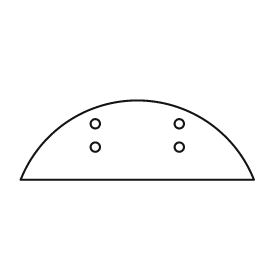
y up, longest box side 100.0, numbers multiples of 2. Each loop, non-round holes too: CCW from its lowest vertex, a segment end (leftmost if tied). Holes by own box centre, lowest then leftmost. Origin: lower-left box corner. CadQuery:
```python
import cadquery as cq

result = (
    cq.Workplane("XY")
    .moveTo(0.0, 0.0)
    .lineTo(100.0, 0.0)
    .threePointArc((50.0, 34.0), (0.0, 0.0))
    .close()
    .moveTo(32.0, 14.0)
    .circle(2.0)
    .moveTo(68.0, 14.0)
    .circle(2.0)
    .moveTo(32.0, 24.0)
    .circle(2.0)
    .moveTo(68.0, 24.0)
    .circle(2.0)
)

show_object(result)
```